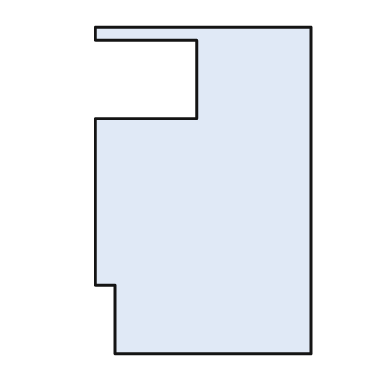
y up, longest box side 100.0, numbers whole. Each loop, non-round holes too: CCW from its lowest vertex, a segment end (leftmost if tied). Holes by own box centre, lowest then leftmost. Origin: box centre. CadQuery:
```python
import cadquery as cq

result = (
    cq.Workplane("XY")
    .moveTo(-27.0, -50.0)
    .lineTo(33.0, -50.0)
    .lineTo(33.0, 50.0)
    .lineTo(-33.0, 50.0)
    .lineTo(-33.0, 46.0)
    .lineTo(-2.0, 46.0)
    .lineTo(-2.0, 22.0)
    .lineTo(-33.0, 22.0)
    .lineTo(-33.0, -29.0)
    .lineTo(-27.0, -29.0)
    .close()
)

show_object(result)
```